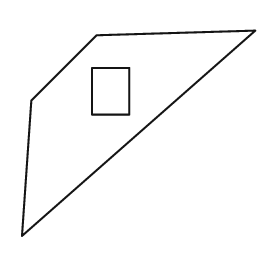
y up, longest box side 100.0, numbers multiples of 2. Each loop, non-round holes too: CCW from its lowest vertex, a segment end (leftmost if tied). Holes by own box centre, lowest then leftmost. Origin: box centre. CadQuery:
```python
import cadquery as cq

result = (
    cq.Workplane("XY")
    .moveTo(-50.0, -44.0)
    .lineTo(50.0, 44.0)
    .lineTo(-18.0, 42.0)
    .lineTo(-46.0, 14.0)
    .close()
    .moveTo(-20.0, 8.0)
    .lineTo(-4.0, 8.0)
    .lineTo(-4.0, 28.0)
    .lineTo(-20.0, 28.0)
    .close()
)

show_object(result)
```